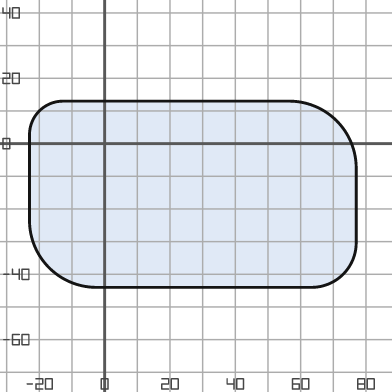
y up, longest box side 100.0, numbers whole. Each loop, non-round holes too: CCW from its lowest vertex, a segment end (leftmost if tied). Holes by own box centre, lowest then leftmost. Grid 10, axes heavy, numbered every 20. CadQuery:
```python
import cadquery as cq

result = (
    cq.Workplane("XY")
    .moveTo(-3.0, -44.0)
    .lineTo(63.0, -44.0)
    .threePointArc((73.0, -40.0), (77.0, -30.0))
    .lineTo(77.0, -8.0)
    .threePointArc((71.0, 7.0), (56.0, 13.0))
    .lineTo(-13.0, 13.0)
    .threePointArc((-20.0, 10.0), (-23.0, 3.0))
    .lineTo(-23.0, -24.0)
    .threePointArc((-17.0, -38.0), (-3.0, -44.0))
    .close()
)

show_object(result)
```